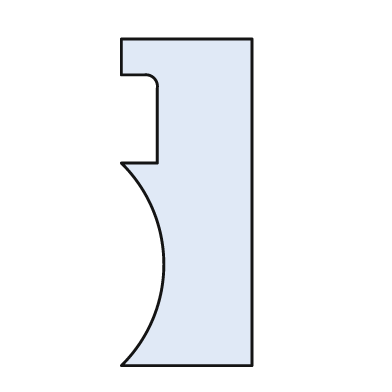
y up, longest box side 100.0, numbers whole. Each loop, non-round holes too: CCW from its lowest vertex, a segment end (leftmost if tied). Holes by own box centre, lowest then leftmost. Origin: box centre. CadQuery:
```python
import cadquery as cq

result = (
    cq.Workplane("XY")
    .moveTo(-20.0, -50.0)
    .lineTo(20.0, -50.0)
    .lineTo(20.0, 50.0)
    .lineTo(-20.0, 50.0)
    .lineTo(-20.0, 39.0)
    .lineTo(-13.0, 39.0)
    .threePointArc((-10.0, 38.0), (-9.0, 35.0))
    .lineTo(-9.0, 12.0)
    .lineTo(-20.0, 12.0)
    .threePointArc((-7.0, -19.0), (-20.0, -50.0))
    .close()
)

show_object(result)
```